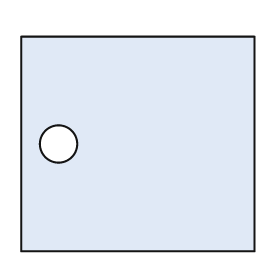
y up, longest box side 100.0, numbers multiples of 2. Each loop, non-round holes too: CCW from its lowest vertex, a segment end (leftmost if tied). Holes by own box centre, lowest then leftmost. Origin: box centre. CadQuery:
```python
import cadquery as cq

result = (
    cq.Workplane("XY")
    .moveTo(-50.0, -46.0)
    .lineTo(50.0, -46.0)
    .lineTo(50.0, 46.0)
    .lineTo(-50.0, 46.0)
    .close()
    .moveTo(-34.0, 0.0)
    .circle(8.0)
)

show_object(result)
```